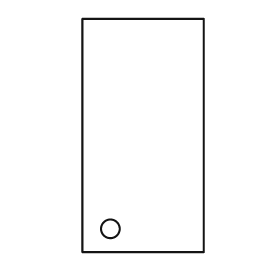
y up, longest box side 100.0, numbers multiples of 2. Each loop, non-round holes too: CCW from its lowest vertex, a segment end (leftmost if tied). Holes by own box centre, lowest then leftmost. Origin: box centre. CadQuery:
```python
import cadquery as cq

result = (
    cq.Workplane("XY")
    .moveTo(-26.0, -50.0)
    .lineTo(26.0, -50.0)
    .lineTo(26.0, 50.0)
    .lineTo(-26.0, 50.0)
    .close()
    .moveTo(-14.0, -40.0)
    .circle(4.0)
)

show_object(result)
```